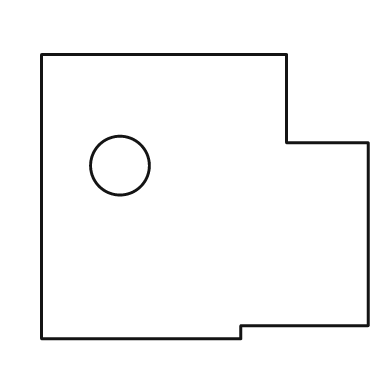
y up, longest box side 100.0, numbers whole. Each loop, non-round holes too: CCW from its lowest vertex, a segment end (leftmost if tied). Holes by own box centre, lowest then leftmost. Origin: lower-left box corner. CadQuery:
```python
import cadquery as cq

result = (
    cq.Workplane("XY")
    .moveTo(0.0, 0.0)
    .lineTo(61.0, 0.0)
    .lineTo(61.0, 4.0)
    .lineTo(100.0, 4.0)
    .lineTo(100.0, 60.0)
    .lineTo(75.0, 60.0)
    .lineTo(75.0, 87.0)
    .lineTo(0.0, 87.0)
    .close()
    .moveTo(24.0, 53.0)
    .circle(9.0)
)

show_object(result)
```